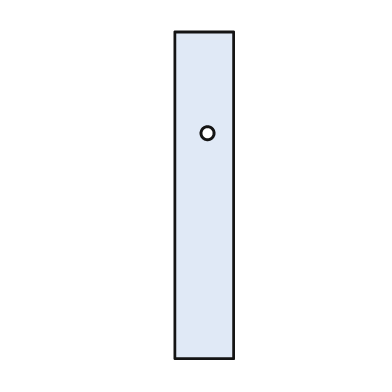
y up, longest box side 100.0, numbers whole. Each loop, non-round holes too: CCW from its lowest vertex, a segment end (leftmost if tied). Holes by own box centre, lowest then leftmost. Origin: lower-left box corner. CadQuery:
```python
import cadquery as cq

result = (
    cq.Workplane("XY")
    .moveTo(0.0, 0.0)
    .lineTo(18.0, 0.0)
    .lineTo(18.0, 100.0)
    .lineTo(0.0, 100.0)
    .close()
    .moveTo(10.0, 69.0)
    .circle(2.0)
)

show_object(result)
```